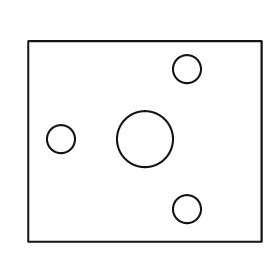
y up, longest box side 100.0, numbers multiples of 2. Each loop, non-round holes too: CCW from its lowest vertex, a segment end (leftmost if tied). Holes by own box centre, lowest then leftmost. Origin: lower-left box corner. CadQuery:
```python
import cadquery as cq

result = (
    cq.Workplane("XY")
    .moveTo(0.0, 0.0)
    .lineTo(100.0, 0.0)
    .lineTo(100.0, 86.0)
    .lineTo(0.0, 86.0)
    .close()
    .moveTo(68.0, 14.0)
    .circle(6.0)
    .moveTo(14.0, 44.0)
    .circle(6.0)
    .moveTo(50.0, 44.0)
    .circle(12.0)
    .moveTo(68.0, 74.0)
    .circle(6.0)
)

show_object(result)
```